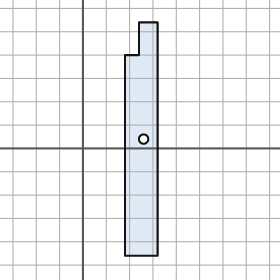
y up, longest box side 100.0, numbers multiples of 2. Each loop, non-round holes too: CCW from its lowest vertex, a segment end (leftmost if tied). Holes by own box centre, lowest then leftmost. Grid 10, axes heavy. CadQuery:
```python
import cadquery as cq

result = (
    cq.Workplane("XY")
    .moveTo(18.0, -46.0)
    .lineTo(32.0, -46.0)
    .lineTo(32.0, 54.0)
    .lineTo(24.0, 54.0)
    .lineTo(24.0, 40.0)
    .lineTo(18.0, 40.0)
    .close()
    .moveTo(26.0, 4.0)
    .circle(2.0)
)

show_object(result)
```